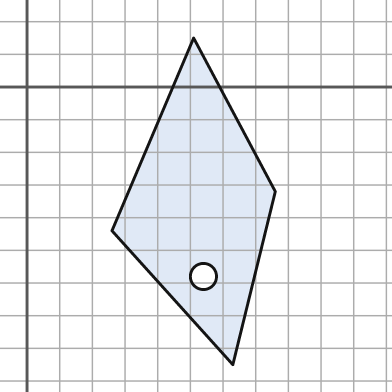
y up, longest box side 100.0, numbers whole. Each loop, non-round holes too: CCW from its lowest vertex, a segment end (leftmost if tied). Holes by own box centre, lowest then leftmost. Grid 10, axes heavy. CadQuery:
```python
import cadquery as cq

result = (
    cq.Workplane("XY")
    .moveTo(63.0, -85.0)
    .lineTo(76.0, -32.0)
    .lineTo(51.0, 15.0)
    .lineTo(26.0, -44.0)
    .close()
    .moveTo(54.0, -58.0)
    .circle(4.0)
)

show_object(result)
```